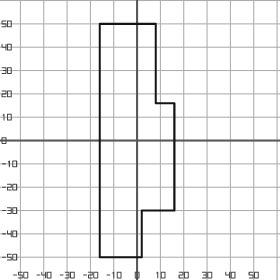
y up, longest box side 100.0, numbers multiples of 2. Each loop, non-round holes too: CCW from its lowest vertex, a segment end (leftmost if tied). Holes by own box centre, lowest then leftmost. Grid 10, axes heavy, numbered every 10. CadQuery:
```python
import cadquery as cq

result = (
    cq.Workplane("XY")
    .moveTo(-16.0, -50.0)
    .lineTo(2.0, -50.0)
    .lineTo(2.0, -30.0)
    .lineTo(16.0, -30.0)
    .lineTo(16.0, 16.0)
    .lineTo(8.0, 16.0)
    .lineTo(8.0, 50.0)
    .lineTo(-16.0, 50.0)
    .close()
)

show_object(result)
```